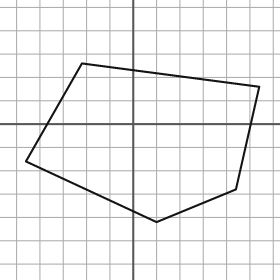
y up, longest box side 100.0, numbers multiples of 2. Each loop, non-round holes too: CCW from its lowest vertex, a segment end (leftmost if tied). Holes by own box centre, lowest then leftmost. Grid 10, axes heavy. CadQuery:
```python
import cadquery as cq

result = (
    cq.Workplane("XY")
    .moveTo(10.0, -42.0)
    .lineTo(44.0, -28.0)
    .lineTo(54.0, 16.0)
    .lineTo(-22.0, 26.0)
    .lineTo(-46.0, -16.0)
    .close()
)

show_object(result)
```